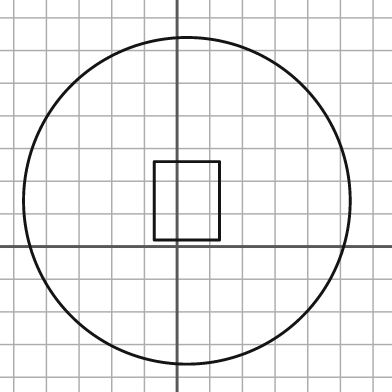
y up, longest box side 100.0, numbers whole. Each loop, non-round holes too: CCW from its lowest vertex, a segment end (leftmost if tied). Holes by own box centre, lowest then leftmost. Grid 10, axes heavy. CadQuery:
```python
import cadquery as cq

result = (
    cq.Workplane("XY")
    .moveTo(3.0, 14.0)
    .circle(50.0)
    .moveTo(-7.0, 2.0)
    .lineTo(13.0, 2.0)
    .lineTo(13.0, 26.0)
    .lineTo(-7.0, 26.0)
    .close()
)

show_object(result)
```